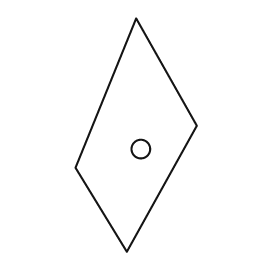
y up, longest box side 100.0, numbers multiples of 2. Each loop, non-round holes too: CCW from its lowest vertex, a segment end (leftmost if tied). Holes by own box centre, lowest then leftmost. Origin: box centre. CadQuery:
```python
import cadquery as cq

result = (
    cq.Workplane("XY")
    .moveTo(-4.0, -50.0)
    .lineTo(26.0, 4.0)
    .lineTo(0.0, 50.0)
    .lineTo(-26.0, -14.0)
    .close()
    .moveTo(2.0, -6.0)
    .circle(4.0)
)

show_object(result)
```